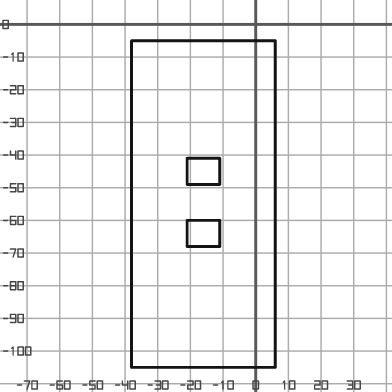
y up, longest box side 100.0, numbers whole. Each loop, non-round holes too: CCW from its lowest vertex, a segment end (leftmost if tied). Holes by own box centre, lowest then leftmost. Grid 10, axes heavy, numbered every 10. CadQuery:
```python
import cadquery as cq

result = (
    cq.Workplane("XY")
    .moveTo(-38.0, -105.0)
    .lineTo(6.0, -105.0)
    .lineTo(6.0, -5.0)
    .lineTo(-38.0, -5.0)
    .close()
    .moveTo(-21.0, -68.0)
    .lineTo(-11.0, -68.0)
    .lineTo(-11.0, -60.0)
    .lineTo(-21.0, -60.0)
    .close()
    .moveTo(-21.0, -49.0)
    .lineTo(-11.0, -49.0)
    .lineTo(-11.0, -41.0)
    .lineTo(-21.0, -41.0)
    .close()
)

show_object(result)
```